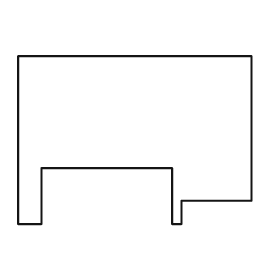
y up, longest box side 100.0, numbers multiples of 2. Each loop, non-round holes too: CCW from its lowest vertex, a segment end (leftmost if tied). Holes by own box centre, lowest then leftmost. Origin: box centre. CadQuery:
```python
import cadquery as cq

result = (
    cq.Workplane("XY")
    .moveTo(-50.0, -36.0)
    .lineTo(-40.0, -36.0)
    .lineTo(-40.0, -12.0)
    .lineTo(16.0, -12.0)
    .lineTo(16.0, -36.0)
    .lineTo(20.0, -36.0)
    .lineTo(20.0, -26.0)
    .lineTo(50.0, -26.0)
    .lineTo(50.0, 36.0)
    .lineTo(-50.0, 36.0)
    .close()
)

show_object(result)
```